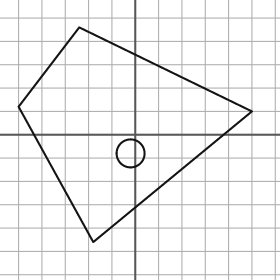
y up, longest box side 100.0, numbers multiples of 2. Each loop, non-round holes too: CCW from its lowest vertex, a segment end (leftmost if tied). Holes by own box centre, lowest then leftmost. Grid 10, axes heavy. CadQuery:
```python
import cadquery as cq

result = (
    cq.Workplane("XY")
    .moveTo(-18.0, -46.0)
    .lineTo(50.0, 10.0)
    .lineTo(-24.0, 46.0)
    .lineTo(-50.0, 12.0)
    .close()
    .moveTo(-2.0, -8.0)
    .circle(6.0)
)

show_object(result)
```